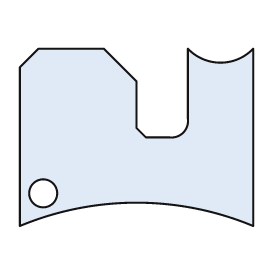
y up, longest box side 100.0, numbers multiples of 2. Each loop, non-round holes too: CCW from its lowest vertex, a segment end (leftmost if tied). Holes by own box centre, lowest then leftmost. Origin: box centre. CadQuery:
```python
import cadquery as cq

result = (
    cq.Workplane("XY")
    .moveTo(-50.0, -38.0)
    .threePointArc((0.0, -28.0), (50.0, -38.0))
    .lineTo(50.0, 38.0)
    .threePointArc((36.0, 32.0), (22.0, 38.0))
    .lineTo(22.0, 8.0)
    .threePointArc((20.0, 2.0), (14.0, 0.0))
    .lineTo(4.0, 0.0)
    .lineTo(0.0, 4.0)
    .lineTo(0.0, 24.0)
    .lineTo(-14.0, 38.0)
    .lineTo(-42.0, 38.0)
    .lineTo(-50.0, 30.0)
    .close()
    .moveTo(-40.0, -24.0)
    .circle(6.0)
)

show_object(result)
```